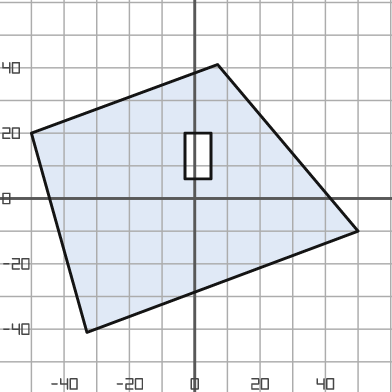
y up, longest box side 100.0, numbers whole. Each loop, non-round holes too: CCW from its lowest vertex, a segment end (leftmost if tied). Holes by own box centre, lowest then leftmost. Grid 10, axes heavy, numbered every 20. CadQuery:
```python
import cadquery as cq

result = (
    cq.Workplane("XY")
    .moveTo(-33.0, -41.0)
    .lineTo(50.0, -10.0)
    .lineTo(7.0, 41.0)
    .lineTo(-50.0, 20.0)
    .close()
    .moveTo(-3.0, 6.0)
    .lineTo(5.0, 6.0)
    .lineTo(5.0, 20.0)
    .lineTo(-3.0, 20.0)
    .close()
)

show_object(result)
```